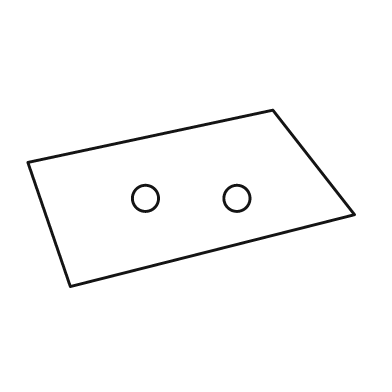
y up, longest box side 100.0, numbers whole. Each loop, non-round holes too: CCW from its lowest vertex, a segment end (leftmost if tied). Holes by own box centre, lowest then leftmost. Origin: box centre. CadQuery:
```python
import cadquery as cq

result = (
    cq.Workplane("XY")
    .moveTo(-37.0, -27.0)
    .lineTo(50.0, -5.0)
    .lineTo(25.0, 27.0)
    .lineTo(-50.0, 11.0)
    .close()
    .moveTo(-14.0, 0.0)
    .circle(4.0)
    .moveTo(14.0, 0.0)
    .circle(4.0)
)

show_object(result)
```